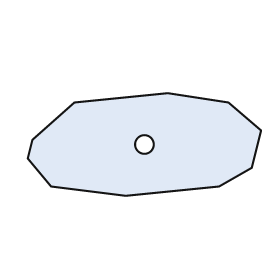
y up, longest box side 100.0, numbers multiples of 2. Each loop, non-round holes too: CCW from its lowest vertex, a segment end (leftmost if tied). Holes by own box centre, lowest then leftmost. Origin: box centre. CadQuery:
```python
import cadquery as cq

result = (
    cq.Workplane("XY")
    .moveTo(-8.0, -22.0)
    .lineTo(32.0, -18.0)
    .lineTo(46.0, -10.0)
    .lineTo(50.0, 6.0)
    .lineTo(36.0, 18.0)
    .lineTo(10.0, 22.0)
    .lineTo(-30.0, 18.0)
    .lineTo(-48.0, 2.0)
    .lineTo(-50.0, -6.0)
    .lineTo(-40.0, -18.0)
    .close()
    .moveTo(0.0, 0.0)
    .circle(4.0)
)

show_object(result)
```